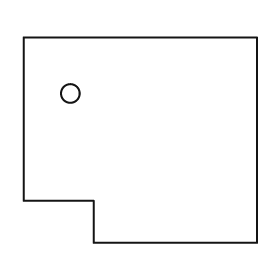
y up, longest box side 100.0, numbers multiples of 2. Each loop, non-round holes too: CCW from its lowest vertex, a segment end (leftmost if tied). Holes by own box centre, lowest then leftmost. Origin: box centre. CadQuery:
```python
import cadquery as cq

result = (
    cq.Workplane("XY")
    .moveTo(-20.0, -44.0)
    .lineTo(50.0, -44.0)
    .lineTo(50.0, 44.0)
    .lineTo(-50.0, 44.0)
    .lineTo(-50.0, -26.0)
    .lineTo(-20.0, -26.0)
    .close()
    .moveTo(-30.0, 20.0)
    .circle(4.0)
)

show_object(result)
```